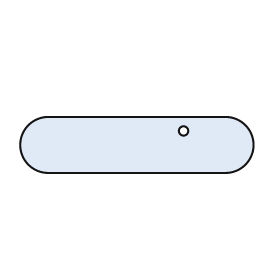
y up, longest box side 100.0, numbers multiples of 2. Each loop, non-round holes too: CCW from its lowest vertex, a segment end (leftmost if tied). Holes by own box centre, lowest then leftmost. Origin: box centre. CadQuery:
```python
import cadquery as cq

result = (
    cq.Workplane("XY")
    .moveTo(-38.0, -12.0)
    .lineTo(38.0, -12.0)
    .threePointArc((50.0, 0.0), (38.0, 12.0))
    .lineTo(-38.0, 12.0)
    .threePointArc((-50.0, 0.0), (-38.0, -12.0))
    .close()
    .moveTo(20.0, 6.0)
    .circle(2.0)
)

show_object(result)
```